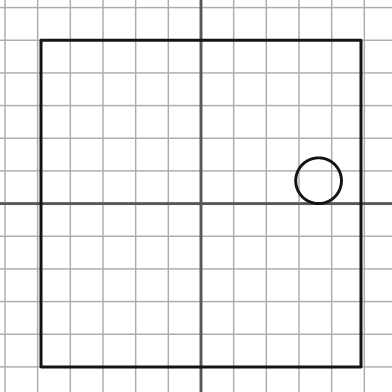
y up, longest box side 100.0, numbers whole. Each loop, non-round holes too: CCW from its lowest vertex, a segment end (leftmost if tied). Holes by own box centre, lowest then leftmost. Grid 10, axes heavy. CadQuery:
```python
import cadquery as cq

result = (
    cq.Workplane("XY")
    .moveTo(-49.0, -50.0)
    .lineTo(49.0, -50.0)
    .lineTo(49.0, 50.0)
    .lineTo(-49.0, 50.0)
    .close()
    .moveTo(36.0, 7.0)
    .circle(7.0)
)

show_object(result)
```